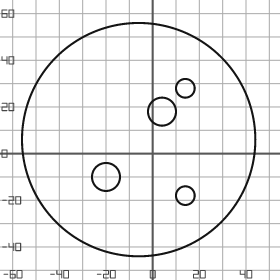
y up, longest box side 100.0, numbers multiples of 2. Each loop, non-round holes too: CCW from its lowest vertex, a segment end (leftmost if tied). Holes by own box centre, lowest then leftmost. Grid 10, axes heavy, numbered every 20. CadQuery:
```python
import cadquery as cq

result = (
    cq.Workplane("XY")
    .moveTo(-6.0, 6.0)
    .circle(50.0)
    .moveTo(14.0, -18.0)
    .circle(4.0)
    .moveTo(-20.0, -10.0)
    .circle(6.0)
    .moveTo(4.0, 18.0)
    .circle(6.0)
    .moveTo(14.0, 28.0)
    .circle(4.0)
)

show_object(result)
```